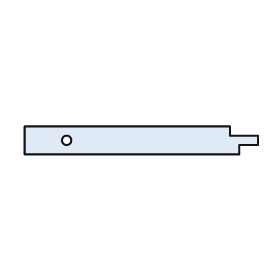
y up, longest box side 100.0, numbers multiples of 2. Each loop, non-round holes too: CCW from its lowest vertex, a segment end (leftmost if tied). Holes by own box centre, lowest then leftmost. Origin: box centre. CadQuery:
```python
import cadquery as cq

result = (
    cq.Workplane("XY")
    .moveTo(-50.0, -6.0)
    .lineTo(42.0, -6.0)
    .lineTo(42.0, -2.0)
    .lineTo(50.0, -2.0)
    .lineTo(50.0, 2.0)
    .lineTo(38.0, 2.0)
    .lineTo(38.0, 6.0)
    .lineTo(-50.0, 6.0)
    .close()
    .moveTo(-32.0, 0.0)
    .circle(2.0)
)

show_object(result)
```